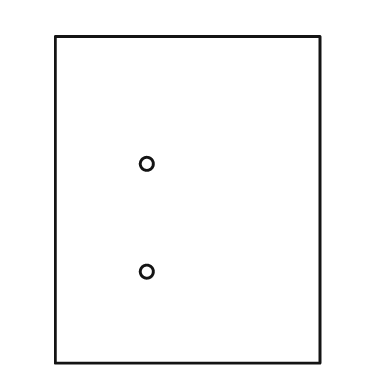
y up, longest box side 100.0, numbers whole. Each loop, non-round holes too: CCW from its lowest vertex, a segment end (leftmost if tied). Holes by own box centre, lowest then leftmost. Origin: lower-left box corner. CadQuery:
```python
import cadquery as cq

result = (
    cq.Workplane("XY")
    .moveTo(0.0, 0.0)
    .lineTo(81.0, 0.0)
    .lineTo(81.0, 100.0)
    .lineTo(0.0, 100.0)
    .close()
    .moveTo(28.0, 28.0)
    .circle(2.0)
    .moveTo(28.0, 61.0)
    .circle(2.0)
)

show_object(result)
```